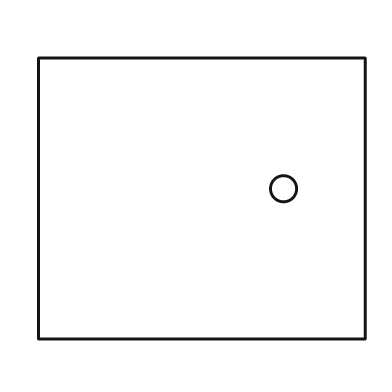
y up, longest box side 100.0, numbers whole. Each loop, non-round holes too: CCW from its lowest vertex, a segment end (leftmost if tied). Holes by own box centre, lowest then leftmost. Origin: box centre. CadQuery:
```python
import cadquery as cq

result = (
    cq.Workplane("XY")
    .moveTo(-50.0, -43.0)
    .lineTo(50.0, -43.0)
    .lineTo(50.0, 43.0)
    .lineTo(-50.0, 43.0)
    .close()
    .moveTo(25.0, 3.0)
    .circle(4.0)
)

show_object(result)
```